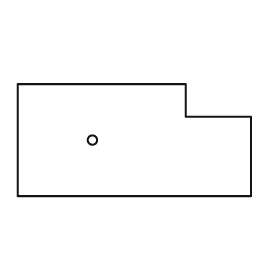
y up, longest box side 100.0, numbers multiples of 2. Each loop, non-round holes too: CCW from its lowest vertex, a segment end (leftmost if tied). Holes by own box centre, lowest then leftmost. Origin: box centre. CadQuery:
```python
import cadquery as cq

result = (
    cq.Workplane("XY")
    .moveTo(-50.0, -24.0)
    .lineTo(50.0, -24.0)
    .lineTo(50.0, 10.0)
    .lineTo(22.0, 10.0)
    .lineTo(22.0, 24.0)
    .lineTo(-50.0, 24.0)
    .close()
    .moveTo(-18.0, 0.0)
    .circle(2.0)
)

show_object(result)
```